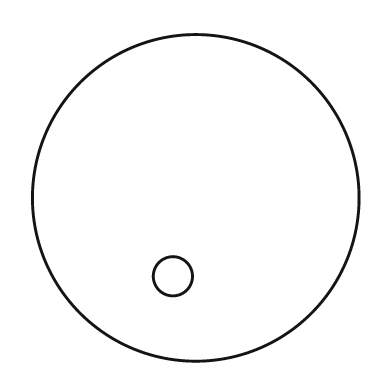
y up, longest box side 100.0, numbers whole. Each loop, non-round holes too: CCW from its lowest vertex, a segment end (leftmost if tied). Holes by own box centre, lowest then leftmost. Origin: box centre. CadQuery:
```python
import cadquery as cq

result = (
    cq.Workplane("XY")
    .moveTo(0.0, 0.0)
    .circle(50.0)
    .moveTo(-7.0, -24.0)
    .circle(6.0)
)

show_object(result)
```